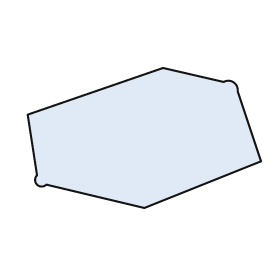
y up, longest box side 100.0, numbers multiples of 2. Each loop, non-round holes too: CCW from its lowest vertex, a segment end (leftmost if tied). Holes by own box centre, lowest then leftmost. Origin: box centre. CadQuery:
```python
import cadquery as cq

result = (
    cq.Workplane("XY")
    .moveTo(0.0, -30.0)
    .lineTo(50.0, -10.0)
    .lineTo(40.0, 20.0)
    .threePointArc((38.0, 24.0), (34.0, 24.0))
    .lineTo(8.0, 30.0)
    .lineTo(-50.0, 10.0)
    .lineTo(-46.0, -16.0)
    .threePointArc((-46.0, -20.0), (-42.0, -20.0))
    .close()
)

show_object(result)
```